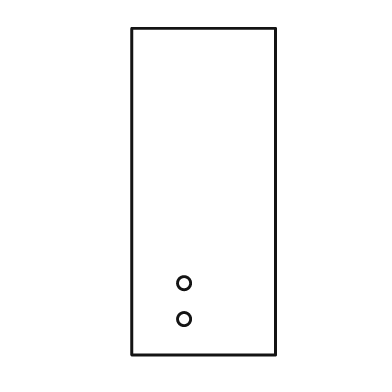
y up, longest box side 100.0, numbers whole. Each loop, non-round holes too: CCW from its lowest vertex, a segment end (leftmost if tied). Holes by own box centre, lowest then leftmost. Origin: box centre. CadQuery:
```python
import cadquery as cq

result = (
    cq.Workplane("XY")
    .moveTo(-22.0, -50.0)
    .lineTo(22.0, -50.0)
    .lineTo(22.0, 50.0)
    .lineTo(-22.0, 50.0)
    .close()
    .moveTo(-6.0, -39.0)
    .circle(2.0)
    .moveTo(-6.0, -28.0)
    .circle(2.0)
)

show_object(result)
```